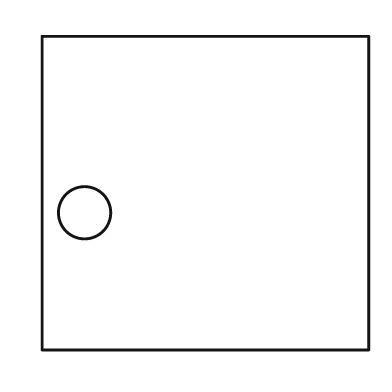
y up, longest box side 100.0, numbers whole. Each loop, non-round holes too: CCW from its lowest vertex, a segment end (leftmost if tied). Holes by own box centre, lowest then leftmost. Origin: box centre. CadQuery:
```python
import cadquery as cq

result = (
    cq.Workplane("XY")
    .moveTo(-50.0, -48.0)
    .lineTo(50.0, -48.0)
    .lineTo(50.0, 48.0)
    .lineTo(-50.0, 48.0)
    .close()
    .moveTo(-37.0, -6.0)
    .circle(8.0)
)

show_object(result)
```